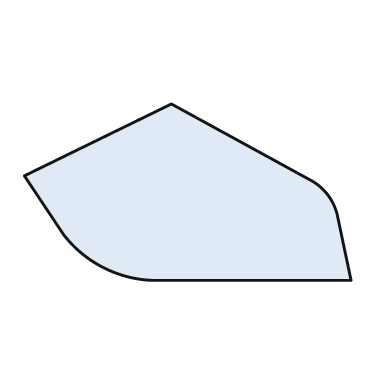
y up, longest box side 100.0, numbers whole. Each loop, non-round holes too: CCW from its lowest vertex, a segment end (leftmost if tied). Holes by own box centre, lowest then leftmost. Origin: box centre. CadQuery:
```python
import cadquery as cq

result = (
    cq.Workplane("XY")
    .moveTo(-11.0, -27.0)
    .lineTo(50.0, -27.0)
    .lineTo(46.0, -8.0)
    .threePointArc((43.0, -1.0), (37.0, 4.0))
    .lineTo(-5.0, 27.0)
    .lineTo(-50.0, 5.0)
    .lineTo(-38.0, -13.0)
    .threePointArc((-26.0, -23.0), (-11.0, -27.0))
    .close()
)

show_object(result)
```